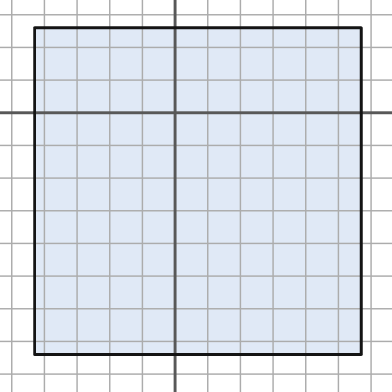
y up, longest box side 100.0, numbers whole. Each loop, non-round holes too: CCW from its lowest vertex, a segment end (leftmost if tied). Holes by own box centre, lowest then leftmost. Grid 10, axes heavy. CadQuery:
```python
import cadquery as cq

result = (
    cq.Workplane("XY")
    .moveTo(-43.0, -74.0)
    .lineTo(57.0, -74.0)
    .lineTo(57.0, 26.0)
    .lineTo(-43.0, 26.0)
    .close()
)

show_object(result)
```